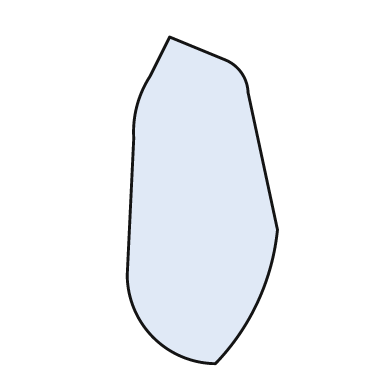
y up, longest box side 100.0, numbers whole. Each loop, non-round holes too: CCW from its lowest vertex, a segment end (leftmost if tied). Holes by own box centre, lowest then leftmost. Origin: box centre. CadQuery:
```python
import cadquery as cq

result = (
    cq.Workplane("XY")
    .moveTo(4.0, -50.0)
    .threePointArc((17.0, -31.0), (23.0, -9.0))
    .lineTo(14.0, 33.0)
    .threePointArc((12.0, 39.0), (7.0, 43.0))
    .lineTo(-10.0, 50.0)
    .lineTo(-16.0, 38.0)
    .threePointArc((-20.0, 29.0), (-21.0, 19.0))
    .lineTo(-23.0, -23.0)
    .threePointArc((-15.0, -42.0), (4.0, -50.0))
    .close()
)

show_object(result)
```